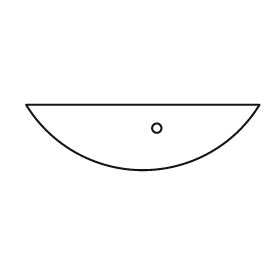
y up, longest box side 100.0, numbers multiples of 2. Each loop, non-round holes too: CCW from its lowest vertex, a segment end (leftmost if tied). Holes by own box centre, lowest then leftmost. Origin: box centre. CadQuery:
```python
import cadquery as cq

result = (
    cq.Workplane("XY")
    .moveTo(-50.0, 14.0)
    .threePointArc((0.0, -14.0), (50.0, 14.0))
    .close()
    .moveTo(6.0, 4.0)
    .circle(2.0)
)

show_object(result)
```